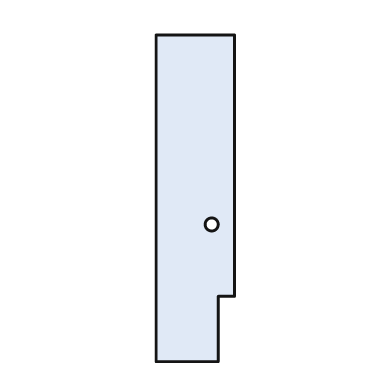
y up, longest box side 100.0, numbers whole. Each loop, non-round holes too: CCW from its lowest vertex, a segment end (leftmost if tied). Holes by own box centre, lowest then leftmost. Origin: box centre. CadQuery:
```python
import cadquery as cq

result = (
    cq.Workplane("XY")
    .moveTo(-12.0, -50.0)
    .lineTo(7.0, -50.0)
    .lineTo(7.0, -30.0)
    .lineTo(12.0, -30.0)
    .lineTo(12.0, 50.0)
    .lineTo(-12.0, 50.0)
    .close()
    .moveTo(5.0, -8.0)
    .circle(2.0)
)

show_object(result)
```